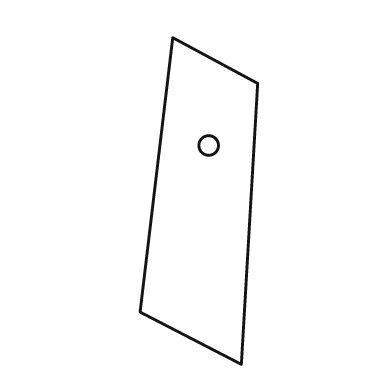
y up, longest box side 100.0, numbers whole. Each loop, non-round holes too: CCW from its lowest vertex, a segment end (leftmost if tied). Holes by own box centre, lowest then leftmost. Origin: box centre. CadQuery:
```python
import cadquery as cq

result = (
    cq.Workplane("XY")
    .moveTo(13.0, -50.0)
    .lineTo(18.0, 36.0)
    .lineTo(-8.0, 50.0)
    .lineTo(-18.0, -34.0)
    .close()
    .moveTo(3.0, 17.0)
    .circle(3.0)
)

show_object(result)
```